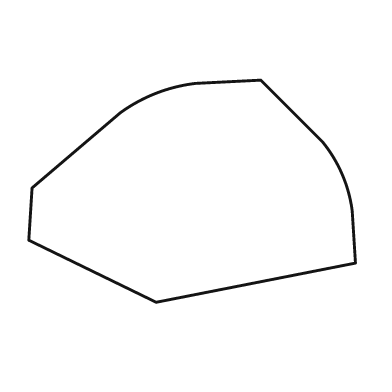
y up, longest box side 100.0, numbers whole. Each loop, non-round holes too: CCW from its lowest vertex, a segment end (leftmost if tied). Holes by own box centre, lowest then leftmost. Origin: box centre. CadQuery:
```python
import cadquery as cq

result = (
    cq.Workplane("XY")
    .moveTo(-11.0, -34.0)
    .lineTo(50.0, -22.0)
    .lineTo(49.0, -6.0)
    .threePointArc((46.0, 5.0), (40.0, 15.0))
    .lineTo(21.0, 34.0)
    .lineTo(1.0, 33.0)
    .threePointArc((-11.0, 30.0), (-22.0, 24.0))
    .lineTo(-49.0, 1.0)
    .lineTo(-50.0, -15.0)
    .close()
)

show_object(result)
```